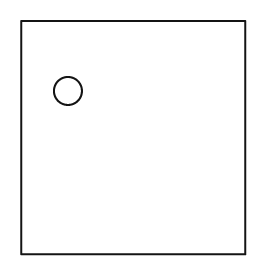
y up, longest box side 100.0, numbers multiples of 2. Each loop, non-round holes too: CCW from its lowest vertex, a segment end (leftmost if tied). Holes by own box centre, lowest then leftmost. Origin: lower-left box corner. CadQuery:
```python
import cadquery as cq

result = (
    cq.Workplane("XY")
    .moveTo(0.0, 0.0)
    .lineTo(96.0, 0.0)
    .lineTo(96.0, 100.0)
    .lineTo(0.0, 100.0)
    .close()
    .moveTo(20.0, 70.0)
    .circle(6.0)
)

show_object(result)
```